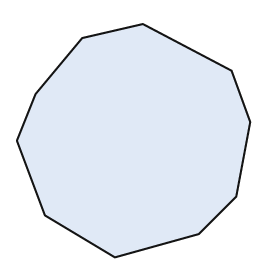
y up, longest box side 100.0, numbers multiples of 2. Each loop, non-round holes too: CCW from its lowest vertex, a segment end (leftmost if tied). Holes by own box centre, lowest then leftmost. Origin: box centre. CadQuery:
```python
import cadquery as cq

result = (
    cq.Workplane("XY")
    .moveTo(-8.0, -50.0)
    .lineTo(28.0, -40.0)
    .lineTo(44.0, -24.0)
    .lineTo(50.0, 8.0)
    .lineTo(42.0, 30.0)
    .lineTo(4.0, 50.0)
    .lineTo(-22.0, 44.0)
    .lineTo(-42.0, 20.0)
    .lineTo(-50.0, 0.0)
    .lineTo(-38.0, -32.0)
    .close()
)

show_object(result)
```